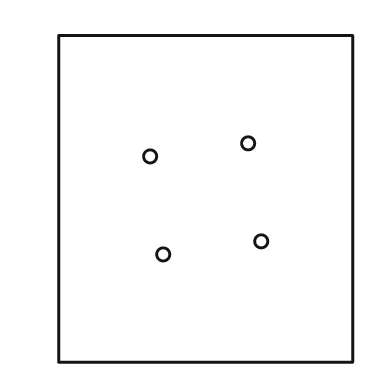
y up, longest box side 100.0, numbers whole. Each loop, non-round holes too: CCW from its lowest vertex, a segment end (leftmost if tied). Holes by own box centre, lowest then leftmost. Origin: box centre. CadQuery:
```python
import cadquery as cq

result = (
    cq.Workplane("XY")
    .moveTo(-45.0, -50.0)
    .lineTo(45.0, -50.0)
    .lineTo(45.0, 50.0)
    .lineTo(-45.0, 50.0)
    .close()
    .moveTo(-13.0, -17.0)
    .circle(2.0)
    .moveTo(17.0, -13.0)
    .circle(2.0)
    .moveTo(-17.0, 13.0)
    .circle(2.0)
    .moveTo(13.0, 17.0)
    .circle(2.0)
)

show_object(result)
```